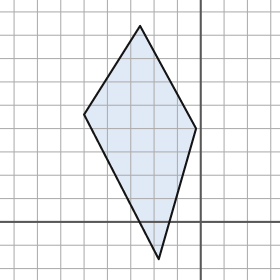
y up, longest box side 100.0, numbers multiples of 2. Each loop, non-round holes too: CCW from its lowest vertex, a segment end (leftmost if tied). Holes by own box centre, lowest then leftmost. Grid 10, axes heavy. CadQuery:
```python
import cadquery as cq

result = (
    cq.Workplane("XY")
    .moveTo(-18.0, -16.0)
    .lineTo(-2.0, 40.0)
    .lineTo(-26.0, 84.0)
    .lineTo(-50.0, 46.0)
    .close()
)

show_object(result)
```